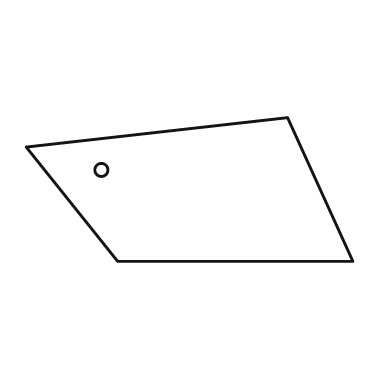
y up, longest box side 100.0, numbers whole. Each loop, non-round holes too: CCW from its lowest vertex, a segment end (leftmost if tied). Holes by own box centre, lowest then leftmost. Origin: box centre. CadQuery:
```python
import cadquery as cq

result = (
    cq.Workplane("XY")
    .moveTo(-22.0, -22.0)
    .lineTo(50.0, -22.0)
    .lineTo(30.0, 22.0)
    .lineTo(-50.0, 13.0)
    .close()
    .moveTo(-27.0, 6.0)
    .circle(2.0)
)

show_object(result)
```